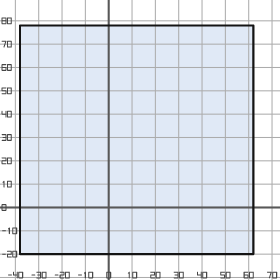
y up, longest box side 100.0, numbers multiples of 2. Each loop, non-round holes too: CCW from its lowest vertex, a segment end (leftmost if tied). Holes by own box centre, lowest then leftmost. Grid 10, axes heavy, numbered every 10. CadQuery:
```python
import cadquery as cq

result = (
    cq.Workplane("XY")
    .moveTo(-38.0, -20.0)
    .lineTo(62.0, -20.0)
    .lineTo(62.0, 78.0)
    .lineTo(-38.0, 78.0)
    .close()
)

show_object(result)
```